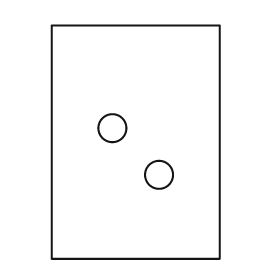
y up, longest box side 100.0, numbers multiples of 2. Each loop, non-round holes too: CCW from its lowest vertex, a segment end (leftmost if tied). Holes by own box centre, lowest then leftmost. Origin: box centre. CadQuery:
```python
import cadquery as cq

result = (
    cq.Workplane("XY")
    .moveTo(-36.0, -50.0)
    .lineTo(36.0, -50.0)
    .lineTo(36.0, 50.0)
    .lineTo(-36.0, 50.0)
    .close()
    .moveTo(10.0, -14.0)
    .circle(6.0)
    .moveTo(-10.0, 6.0)
    .circle(6.0)
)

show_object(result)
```